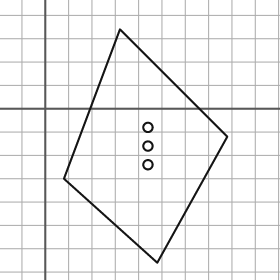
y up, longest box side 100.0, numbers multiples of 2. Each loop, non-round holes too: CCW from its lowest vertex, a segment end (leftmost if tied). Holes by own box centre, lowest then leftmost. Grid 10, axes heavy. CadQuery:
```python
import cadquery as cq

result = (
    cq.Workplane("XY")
    .moveTo(48.0, -66.0)
    .lineTo(78.0, -12.0)
    .lineTo(32.0, 34.0)
    .lineTo(8.0, -30.0)
    .close()
    .moveTo(44.0, -24.0)
    .circle(2.0)
    .moveTo(44.0, -16.0)
    .circle(2.0)
    .moveTo(44.0, -8.0)
    .circle(2.0)
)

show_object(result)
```